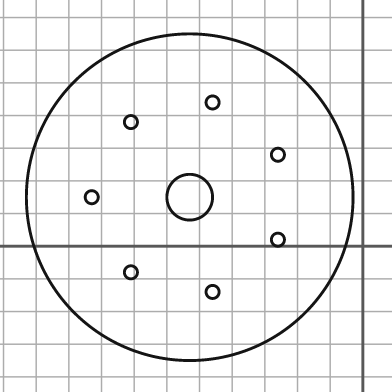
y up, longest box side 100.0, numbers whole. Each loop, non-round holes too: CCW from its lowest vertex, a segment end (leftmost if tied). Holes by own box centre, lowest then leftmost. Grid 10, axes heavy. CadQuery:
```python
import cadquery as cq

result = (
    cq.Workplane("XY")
    .moveTo(-53.0, 15.0)
    .circle(50.0)
    .moveTo(-46.0, -14.0)
    .circle(2.0)
    .moveTo(-71.0, -8.0)
    .circle(2.0)
    .moveTo(-26.0, 2.0)
    .circle(2.0)
    .moveTo(-83.0, 15.0)
    .circle(2.0)
    .moveTo(-53.0, 15.0)
    .circle(7.0)
    .moveTo(-26.0, 28.0)
    .circle(2.0)
    .moveTo(-71.0, 38.0)
    .circle(2.0)
    .moveTo(-46.0, 44.0)
    .circle(2.0)
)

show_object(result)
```